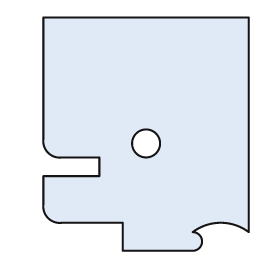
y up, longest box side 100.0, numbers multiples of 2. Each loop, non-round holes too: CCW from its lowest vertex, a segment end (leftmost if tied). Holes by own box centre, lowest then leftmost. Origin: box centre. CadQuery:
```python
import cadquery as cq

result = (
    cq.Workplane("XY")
    .moveTo(-10.0, -50.0)
    .lineTo(20.0, -50.0)
    .threePointArc((24.0, -46.0), (20.0, -42.0))
    .threePointArc((32.0, -38.0), (44.0, -42.0))
    .lineTo(44.0, 50.0)
    .lineTo(-44.0, 50.0)
    .lineTo(-44.0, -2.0)
    .threePointArc((-42.0, -8.0), (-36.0, -10.0))
    .lineTo(-20.0, -10.0)
    .lineTo(-20.0, -18.0)
    .lineTo(-44.0, -18.0)
    .lineTo(-44.0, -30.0)
    .threePointArc((-42.0, -36.0), (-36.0, -38.0))
    .lineTo(-10.0, -38.0)
    .close()
    .moveTo(0.0, -4.0)
    .circle(6.0)
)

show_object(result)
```